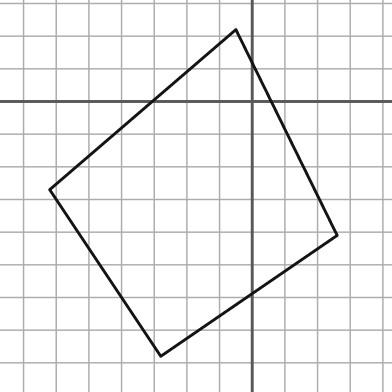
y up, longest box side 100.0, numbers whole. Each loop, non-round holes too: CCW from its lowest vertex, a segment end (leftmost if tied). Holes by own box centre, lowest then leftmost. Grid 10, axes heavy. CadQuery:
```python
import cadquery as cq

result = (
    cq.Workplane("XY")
    .moveTo(-28.0, -78.0)
    .lineTo(26.0, -41.0)
    .lineTo(-5.0, 22.0)
    .lineTo(-62.0, -27.0)
    .close()
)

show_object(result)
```